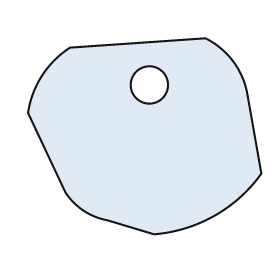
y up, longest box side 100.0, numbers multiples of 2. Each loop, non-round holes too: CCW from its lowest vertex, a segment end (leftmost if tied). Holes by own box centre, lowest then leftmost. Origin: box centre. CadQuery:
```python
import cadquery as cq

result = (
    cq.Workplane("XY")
    .moveTo(4.0, -42.0)
    .threePointArc((30.0, -34.0), (50.0, -16.0))
    .lineTo(44.0, 18.0)
    .threePointArc((38.0, 32.0), (26.0, 42.0))
    .lineTo(-32.0, 38.0)
    .threePointArc((-44.0, 26.0), (-50.0, 10.0))
    .lineTo(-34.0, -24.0)
    .threePointArc((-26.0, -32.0), (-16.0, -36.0))
    .close()
    .moveTo(2.0, 22.0)
    .circle(8.0)
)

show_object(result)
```